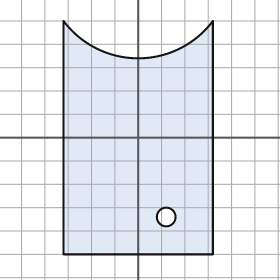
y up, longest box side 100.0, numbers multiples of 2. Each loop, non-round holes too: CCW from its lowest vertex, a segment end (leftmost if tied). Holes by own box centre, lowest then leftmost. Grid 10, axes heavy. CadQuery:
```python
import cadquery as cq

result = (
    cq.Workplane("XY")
    .moveTo(-32.0, -50.0)
    .lineTo(32.0, -50.0)
    .lineTo(32.0, 50.0)
    .threePointArc((0.0, 34.0), (-32.0, 50.0))
    .close()
    .moveTo(12.0, -34.0)
    .circle(4.0)
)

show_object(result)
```